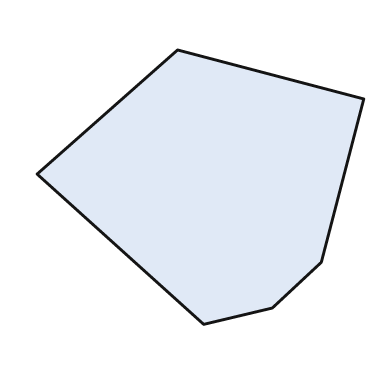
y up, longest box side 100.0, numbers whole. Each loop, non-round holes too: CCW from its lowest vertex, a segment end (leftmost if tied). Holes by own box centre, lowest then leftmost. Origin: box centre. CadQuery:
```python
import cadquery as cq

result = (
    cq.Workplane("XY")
    .moveTo(1.0, -42.0)
    .lineTo(22.0, -37.0)
    .lineTo(37.0, -23.0)
    .lineTo(50.0, 27.0)
    .lineTo(-7.0, 42.0)
    .lineTo(-50.0, 4.0)
    .close()
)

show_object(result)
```